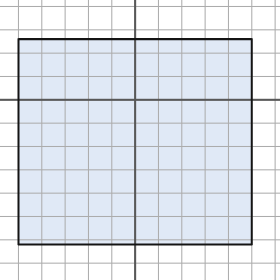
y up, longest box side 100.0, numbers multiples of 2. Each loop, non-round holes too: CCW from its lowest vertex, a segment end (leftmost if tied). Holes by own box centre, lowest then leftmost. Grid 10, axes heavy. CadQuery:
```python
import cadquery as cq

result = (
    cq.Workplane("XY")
    .moveTo(-50.0, -62.0)
    .lineTo(50.0, -62.0)
    .lineTo(50.0, 26.0)
    .lineTo(-50.0, 26.0)
    .close()
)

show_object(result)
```